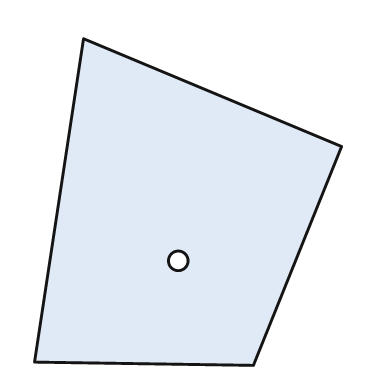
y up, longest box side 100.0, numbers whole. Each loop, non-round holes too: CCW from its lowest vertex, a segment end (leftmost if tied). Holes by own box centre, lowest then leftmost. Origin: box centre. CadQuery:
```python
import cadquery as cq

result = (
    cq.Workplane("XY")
    .moveTo(20.0, -50.0)
    .lineTo(47.0, 17.0)
    .lineTo(-32.0, 50.0)
    .lineTo(-47.0, -49.0)
    .close()
    .moveTo(-3.0, -18.0)
    .circle(3.0)
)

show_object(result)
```